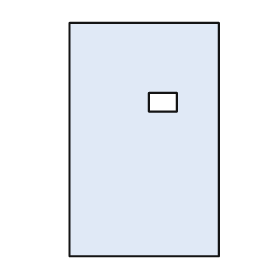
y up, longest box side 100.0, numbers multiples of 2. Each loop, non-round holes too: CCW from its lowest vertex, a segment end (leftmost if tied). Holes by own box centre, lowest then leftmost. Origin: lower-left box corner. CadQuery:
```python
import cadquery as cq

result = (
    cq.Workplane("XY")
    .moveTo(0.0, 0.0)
    .lineTo(64.0, 0.0)
    .lineTo(64.0, 100.0)
    .lineTo(0.0, 100.0)
    .close()
    .moveTo(34.0, 62.0)
    .lineTo(46.0, 62.0)
    .lineTo(46.0, 70.0)
    .lineTo(34.0, 70.0)
    .close()
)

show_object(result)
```